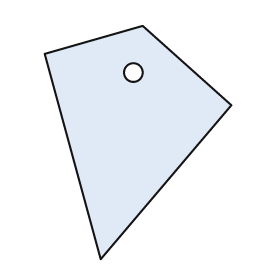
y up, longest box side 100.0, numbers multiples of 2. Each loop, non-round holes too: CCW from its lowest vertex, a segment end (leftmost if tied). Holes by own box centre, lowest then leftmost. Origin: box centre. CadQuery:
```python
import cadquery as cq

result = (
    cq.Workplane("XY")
    .moveTo(-16.0, -50.0)
    .lineTo(40.0, 16.0)
    .lineTo(2.0, 50.0)
    .lineTo(-40.0, 38.0)
    .close()
    .moveTo(-2.0, 30.0)
    .circle(4.0)
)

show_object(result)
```